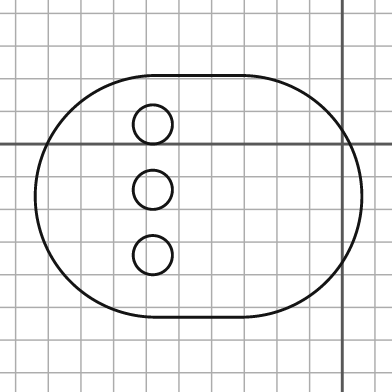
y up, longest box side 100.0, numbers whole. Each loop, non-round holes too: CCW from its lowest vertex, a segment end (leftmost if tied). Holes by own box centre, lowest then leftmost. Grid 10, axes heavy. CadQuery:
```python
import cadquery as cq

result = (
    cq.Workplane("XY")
    .moveTo(-57.0, -53.0)
    .lineTo(-31.0, -53.0)
    .threePointArc((6.0, -16.0), (-31.0, 21.0))
    .lineTo(-57.0, 21.0)
    .threePointArc((-94.0, -16.0), (-57.0, -53.0))
    .close()
    .moveTo(-58.0, -34.0)
    .circle(6.0)
    .moveTo(-58.0, -14.0)
    .circle(6.0)
    .moveTo(-58.0, 6.0)
    .circle(6.0)
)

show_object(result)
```